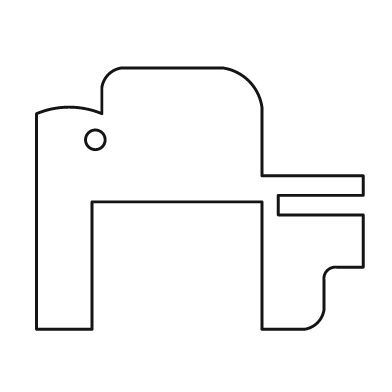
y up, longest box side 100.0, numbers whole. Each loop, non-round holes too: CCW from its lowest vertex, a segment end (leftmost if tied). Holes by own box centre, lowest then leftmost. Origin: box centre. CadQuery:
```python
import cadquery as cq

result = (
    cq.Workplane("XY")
    .moveTo(-50.0, -40.0)
    .lineTo(-33.0, -40.0)
    .lineTo(-33.0, -1.0)
    .lineTo(19.0, -1.0)
    .lineTo(19.0, -40.0)
    .lineTo(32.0, -40.0)
    .threePointArc((36.0, -38.0), (38.0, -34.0))
    .lineTo(38.0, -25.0)
    .threePointArc((39.0, -22.0), (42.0, -21.0))
    .lineTo(50.0, -21.0)
    .lineTo(50.0, -5.0)
    .lineTo(24.0, -5.0)
    .lineTo(24.0, 1.0)
    .lineTo(50.0, 1.0)
    .lineTo(50.0, 7.0)
    .lineTo(19.0, 7.0)
    .lineTo(19.0, 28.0)
    .threePointArc((15.0, 36.0), (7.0, 40.0))
    .lineTo(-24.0, 40.0)
    .threePointArc((-28.0, 38.0), (-30.0, 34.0))
    .lineTo(-30.0, 26.0)
    .threePointArc((-40.0, 28.0), (-50.0, 26.0))
    .close()
    .moveTo(-32.0, 18.0)
    .circle(3.0)
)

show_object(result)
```